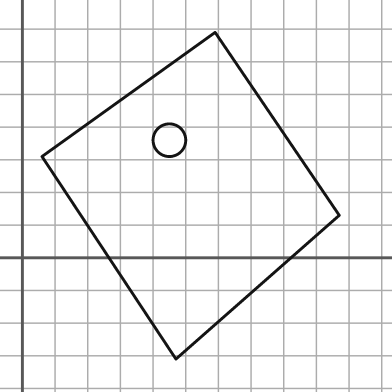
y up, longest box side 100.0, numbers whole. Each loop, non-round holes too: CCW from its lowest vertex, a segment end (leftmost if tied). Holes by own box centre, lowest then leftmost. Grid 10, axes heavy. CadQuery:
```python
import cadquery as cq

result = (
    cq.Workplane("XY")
    .moveTo(47.0, -31.0)
    .lineTo(97.0, 13.0)
    .lineTo(59.0, 69.0)
    .lineTo(6.0, 31.0)
    .close()
    .moveTo(45.0, 36.0)
    .circle(5.0)
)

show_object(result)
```